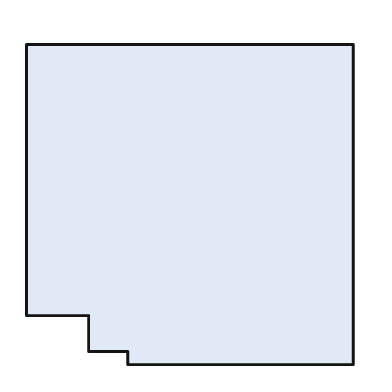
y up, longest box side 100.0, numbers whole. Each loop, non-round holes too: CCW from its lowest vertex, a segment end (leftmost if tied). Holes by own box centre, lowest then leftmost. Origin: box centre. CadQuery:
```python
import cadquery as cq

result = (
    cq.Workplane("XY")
    .moveTo(-19.0, -49.0)
    .lineTo(50.0, -49.0)
    .lineTo(50.0, 49.0)
    .lineTo(-50.0, 49.0)
    .lineTo(-50.0, -34.0)
    .lineTo(-31.0, -34.0)
    .lineTo(-31.0, -45.0)
    .lineTo(-19.0, -45.0)
    .close()
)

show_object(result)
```